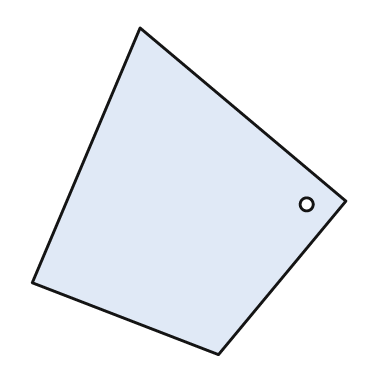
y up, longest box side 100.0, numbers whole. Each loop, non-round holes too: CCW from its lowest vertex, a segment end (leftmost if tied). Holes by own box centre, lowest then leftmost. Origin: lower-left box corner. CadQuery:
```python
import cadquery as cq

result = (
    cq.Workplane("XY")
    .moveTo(57.0, 0.0)
    .lineTo(96.0, 47.0)
    .lineTo(33.0, 100.0)
    .lineTo(0.0, 22.0)
    .close()
    .moveTo(84.0, 46.0)
    .circle(2.0)
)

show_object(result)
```